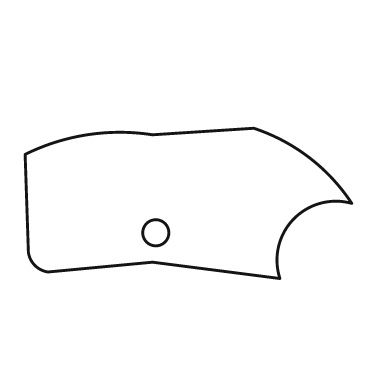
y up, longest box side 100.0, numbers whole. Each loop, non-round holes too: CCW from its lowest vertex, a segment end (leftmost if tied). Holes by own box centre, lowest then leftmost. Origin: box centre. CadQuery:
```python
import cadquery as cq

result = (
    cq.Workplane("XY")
    .moveTo(28.0, -23.0)
    .threePointArc((32.0, -5.0), (50.0, 0.0))
    .threePointArc((37.0, 14.0), (20.0, 23.0))
    .lineTo(-11.0, 21.0)
    .threePointArc((-31.0, 21.0), (-50.0, 15.0))
    .lineTo(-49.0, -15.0)
    .threePointArc((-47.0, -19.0), (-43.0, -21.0))
    .lineTo(-11.0, -18.0)
    .close()
    .moveTo(-10.0, -9.0)
    .circle(4.0)
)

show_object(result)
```